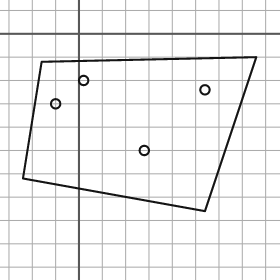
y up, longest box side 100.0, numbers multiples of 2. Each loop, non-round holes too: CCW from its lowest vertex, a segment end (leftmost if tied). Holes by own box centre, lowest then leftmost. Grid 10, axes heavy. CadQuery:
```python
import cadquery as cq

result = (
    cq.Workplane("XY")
    .moveTo(54.0, -76.0)
    .lineTo(76.0, -10.0)
    .lineTo(-16.0, -12.0)
    .lineTo(-24.0, -62.0)
    .close()
    .moveTo(28.0, -50.0)
    .circle(2.0)
    .moveTo(-10.0, -30.0)
    .circle(2.0)
    .moveTo(54.0, -24.0)
    .circle(2.0)
    .moveTo(2.0, -20.0)
    .circle(2.0)
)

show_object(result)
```